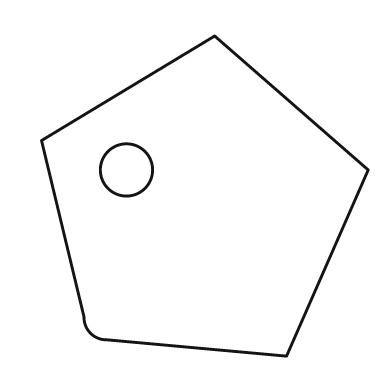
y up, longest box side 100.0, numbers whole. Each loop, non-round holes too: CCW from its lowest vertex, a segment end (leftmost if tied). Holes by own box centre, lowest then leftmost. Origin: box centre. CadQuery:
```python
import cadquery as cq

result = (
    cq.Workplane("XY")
    .moveTo(25.0, -49.0)
    .lineTo(50.0, 8.0)
    .lineTo(3.0, 49.0)
    .lineTo(-50.0, 17.0)
    .lineTo(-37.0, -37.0)
    .threePointArc((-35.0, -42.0), (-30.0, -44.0))
    .close()
    .moveTo(-24.0, 8.0)
    .circle(8.0)
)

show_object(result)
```